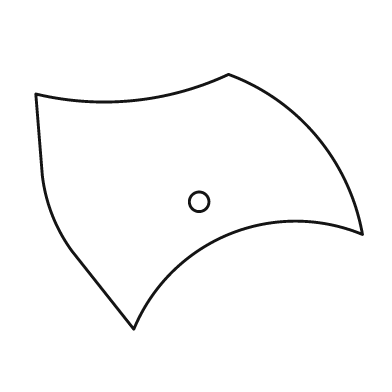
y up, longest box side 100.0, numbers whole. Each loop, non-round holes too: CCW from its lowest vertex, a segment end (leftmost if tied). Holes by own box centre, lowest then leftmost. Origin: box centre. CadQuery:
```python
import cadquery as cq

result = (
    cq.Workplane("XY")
    .moveTo(-20.0, -39.0)
    .threePointArc((9.0, -10.0), (50.0, -10.0))
    .threePointArc((36.0, 20.0), (9.0, 39.0))
    .threePointArc((-20.0, 31.0), (-50.0, 33.0))
    .lineTo(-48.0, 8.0)
    .threePointArc((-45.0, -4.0), (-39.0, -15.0))
    .close()
    .moveTo(0.0, 0.0)
    .circle(3.0)
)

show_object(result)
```